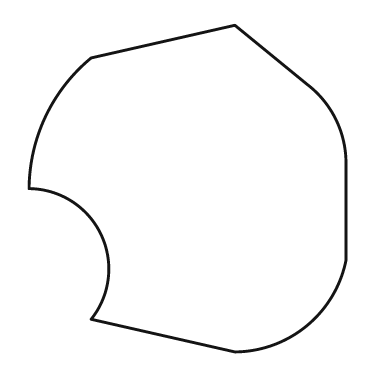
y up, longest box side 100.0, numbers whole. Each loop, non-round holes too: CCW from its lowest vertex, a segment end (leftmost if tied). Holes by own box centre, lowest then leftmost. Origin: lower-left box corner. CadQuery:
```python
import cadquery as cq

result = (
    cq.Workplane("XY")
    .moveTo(63.0, 0.0)
    .threePointArc((85.0, 8.0), (97.0, 28.0))
    .lineTo(97.0, 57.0)
    .threePointArc((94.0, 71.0), (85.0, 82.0))
    .lineTo(63.0, 100.0)
    .lineTo(19.0, 90.0)
    .threePointArc((5.0, 72.0), (0.0, 50.0))
    .threePointArc((22.0, 36.0), (19.0, 10.0))
    .close()
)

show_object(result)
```